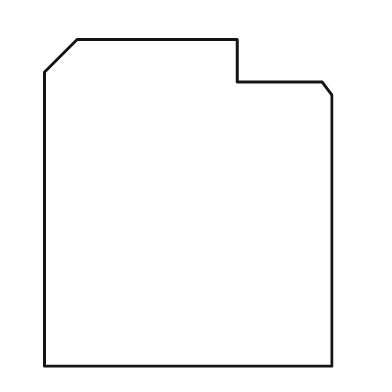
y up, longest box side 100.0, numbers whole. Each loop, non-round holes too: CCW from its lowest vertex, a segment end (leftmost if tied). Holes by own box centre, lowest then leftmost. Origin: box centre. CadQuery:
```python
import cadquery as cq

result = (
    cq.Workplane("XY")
    .moveTo(-44.0, -50.0)
    .lineTo(44.0, -50.0)
    .lineTo(44.0, 33.0)
    .lineTo(41.0, 37.0)
    .lineTo(15.0, 37.0)
    .lineTo(15.0, 50.0)
    .lineTo(-34.0, 50.0)
    .lineTo(-44.0, 40.0)
    .close()
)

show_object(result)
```